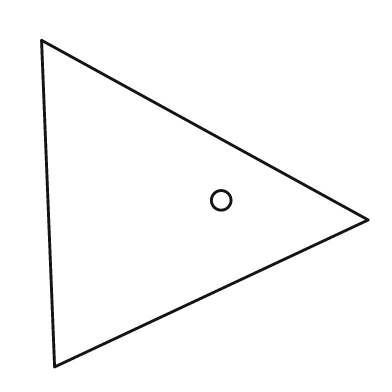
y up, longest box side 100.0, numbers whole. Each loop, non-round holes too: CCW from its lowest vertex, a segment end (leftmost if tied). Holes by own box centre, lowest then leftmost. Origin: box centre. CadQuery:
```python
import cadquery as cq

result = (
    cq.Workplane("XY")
    .moveTo(-46.0, -50.0)
    .lineTo(50.0, -5.0)
    .lineTo(-50.0, 50.0)
    .close()
    .moveTo(5.0, 1.0)
    .circle(3.0)
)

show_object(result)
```